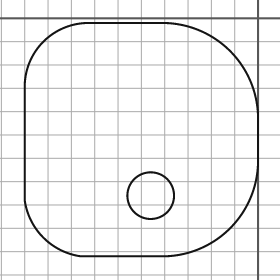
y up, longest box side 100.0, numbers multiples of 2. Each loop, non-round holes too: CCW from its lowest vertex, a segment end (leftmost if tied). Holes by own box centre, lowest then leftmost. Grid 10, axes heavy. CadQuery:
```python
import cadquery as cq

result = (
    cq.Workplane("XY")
    .moveTo(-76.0, -102.0)
    .lineTo(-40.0, -102.0)
    .threePointArc((-12.0, -90.0), (0.0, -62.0))
    .lineTo(0.0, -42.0)
    .threePointArc((-12.0, -14.0), (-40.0, -2.0))
    .lineTo(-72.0, -2.0)
    .threePointArc((-92.0, -10.0), (-100.0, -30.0))
    .lineTo(-100.0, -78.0)
    .threePointArc((-92.0, -94.0), (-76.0, -102.0))
    .close()
    .moveTo(-46.0, -76.0)
    .circle(10.0)
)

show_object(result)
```